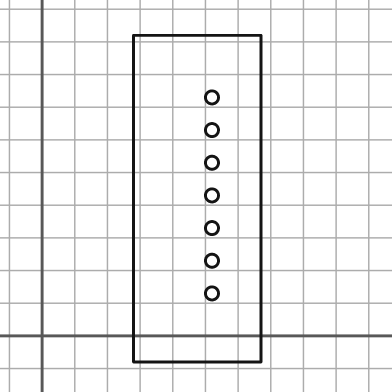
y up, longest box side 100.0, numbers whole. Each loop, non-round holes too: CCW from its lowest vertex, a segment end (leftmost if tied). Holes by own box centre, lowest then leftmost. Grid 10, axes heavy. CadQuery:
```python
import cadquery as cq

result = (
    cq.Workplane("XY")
    .moveTo(28.0, -8.0)
    .lineTo(67.0, -8.0)
    .lineTo(67.0, 92.0)
    .lineTo(28.0, 92.0)
    .close()
    .moveTo(52.0, 13.0)
    .circle(2.0)
    .moveTo(52.0, 23.0)
    .circle(2.0)
    .moveTo(52.0, 33.0)
    .circle(2.0)
    .moveTo(52.0, 43.0)
    .circle(2.0)
    .moveTo(52.0, 53.0)
    .circle(2.0)
    .moveTo(52.0, 63.0)
    .circle(2.0)
    .moveTo(52.0, 73.0)
    .circle(2.0)
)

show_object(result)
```